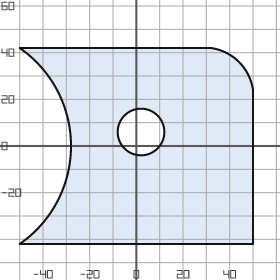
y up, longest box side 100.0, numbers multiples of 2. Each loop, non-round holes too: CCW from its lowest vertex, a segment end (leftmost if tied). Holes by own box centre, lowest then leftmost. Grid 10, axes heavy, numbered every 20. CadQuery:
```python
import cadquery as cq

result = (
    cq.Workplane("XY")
    .moveTo(-50.0, -42.0)
    .lineTo(50.0, -42.0)
    .lineTo(50.0, 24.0)
    .threePointArc((44.0, 36.0), (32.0, 42.0))
    .lineTo(-50.0, 42.0)
    .threePointArc((-28.0, 0.0), (-50.0, -42.0))
    .close()
    .moveTo(2.0, 6.0)
    .circle(10.0)
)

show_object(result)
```